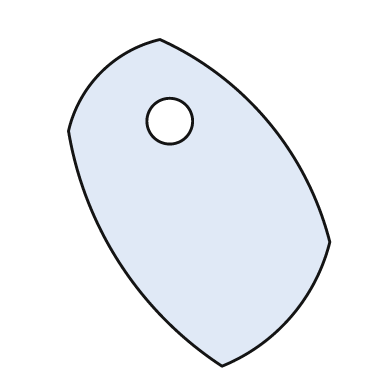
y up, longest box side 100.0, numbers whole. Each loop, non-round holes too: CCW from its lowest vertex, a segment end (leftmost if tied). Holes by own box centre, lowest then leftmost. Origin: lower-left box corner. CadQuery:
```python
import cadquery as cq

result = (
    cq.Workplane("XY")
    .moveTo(47.0, 0.0)
    .threePointArc((68.0, 15.0), (80.0, 38.0))
    .threePointArc((61.0, 75.0), (28.0, 100.0))
    .threePointArc((10.0, 90.0), (0.0, 72.0))
    .threePointArc((16.0, 31.0), (47.0, 0.0))
    .close()
    .moveTo(31.0, 75.0)
    .circle(7.0)
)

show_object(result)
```